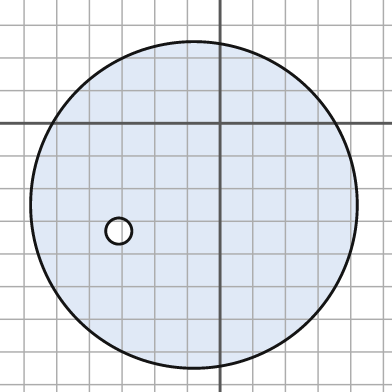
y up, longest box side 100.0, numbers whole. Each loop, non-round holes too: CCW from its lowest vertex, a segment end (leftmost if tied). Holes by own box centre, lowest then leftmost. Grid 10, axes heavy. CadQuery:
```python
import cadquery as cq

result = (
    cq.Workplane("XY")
    .moveTo(-8.0, -25.0)
    .circle(50.0)
    .moveTo(-31.0, -33.0)
    .circle(4.0)
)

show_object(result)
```